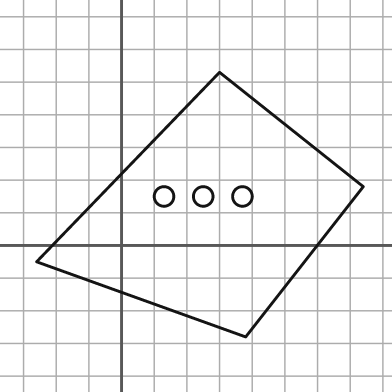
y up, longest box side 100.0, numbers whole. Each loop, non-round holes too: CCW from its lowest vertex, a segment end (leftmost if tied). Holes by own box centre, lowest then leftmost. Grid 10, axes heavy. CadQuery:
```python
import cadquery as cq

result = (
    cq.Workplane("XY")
    .moveTo(38.0, -28.0)
    .lineTo(74.0, 18.0)
    .lineTo(30.0, 53.0)
    .lineTo(-26.0, -5.0)
    .close()
    .moveTo(13.0, 15.0)
    .circle(3.0)
    .moveTo(25.0, 15.0)
    .circle(3.0)
    .moveTo(37.0, 15.0)
    .circle(3.0)
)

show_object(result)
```